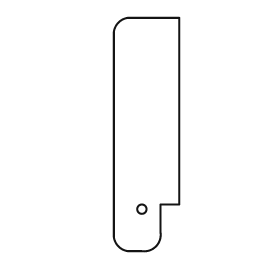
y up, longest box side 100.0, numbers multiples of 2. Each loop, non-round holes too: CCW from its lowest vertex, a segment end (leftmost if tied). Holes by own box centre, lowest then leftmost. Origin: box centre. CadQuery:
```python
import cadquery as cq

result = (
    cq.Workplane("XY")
    .moveTo(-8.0, -50.0)
    .lineTo(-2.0, -50.0)
    .threePointArc((4.0, -48.0), (6.0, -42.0))
    .lineTo(6.0, -30.0)
    .lineTo(14.0, -30.0)
    .lineTo(14.0, 50.0)
    .lineTo(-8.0, 50.0)
    .threePointArc((-12.0, 48.0), (-14.0, 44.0))
    .lineTo(-14.0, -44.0)
    .threePointArc((-12.0, -48.0), (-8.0, -50.0))
    .close()
    .moveTo(-2.0, -32.0)
    .circle(2.0)
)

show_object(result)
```